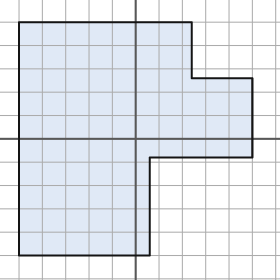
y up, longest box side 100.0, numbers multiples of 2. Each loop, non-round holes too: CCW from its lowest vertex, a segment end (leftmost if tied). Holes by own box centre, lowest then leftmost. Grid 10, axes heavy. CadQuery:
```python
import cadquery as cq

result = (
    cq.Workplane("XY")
    .moveTo(-50.0, -50.0)
    .lineTo(6.0, -50.0)
    .lineTo(6.0, -8.0)
    .lineTo(50.0, -8.0)
    .lineTo(50.0, 26.0)
    .lineTo(24.0, 26.0)
    .lineTo(24.0, 50.0)
    .lineTo(-50.0, 50.0)
    .close()
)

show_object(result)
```